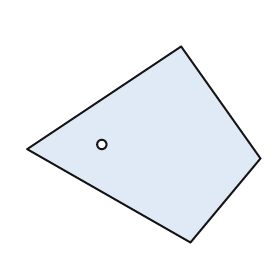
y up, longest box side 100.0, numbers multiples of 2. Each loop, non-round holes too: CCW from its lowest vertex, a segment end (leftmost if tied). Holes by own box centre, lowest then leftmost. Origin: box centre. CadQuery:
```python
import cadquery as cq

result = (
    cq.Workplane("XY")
    .moveTo(20.0, -42.0)
    .lineTo(50.0, -6.0)
    .lineTo(16.0, 42.0)
    .lineTo(-50.0, -2.0)
    .close()
    .moveTo(-18.0, 0.0)
    .circle(2.0)
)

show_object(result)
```